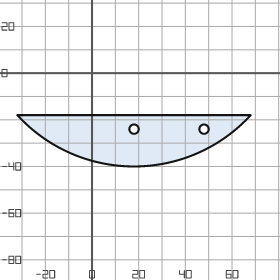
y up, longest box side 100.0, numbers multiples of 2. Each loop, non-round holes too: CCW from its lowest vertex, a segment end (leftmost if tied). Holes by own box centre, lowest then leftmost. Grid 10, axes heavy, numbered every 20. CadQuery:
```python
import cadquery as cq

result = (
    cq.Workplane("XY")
    .moveTo(-32.0, -18.0)
    .threePointArc((18.0, -40.0), (68.0, -18.0))
    .close()
    .moveTo(18.0, -24.0)
    .circle(2.0)
    .moveTo(48.0, -24.0)
    .circle(2.0)
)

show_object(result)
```